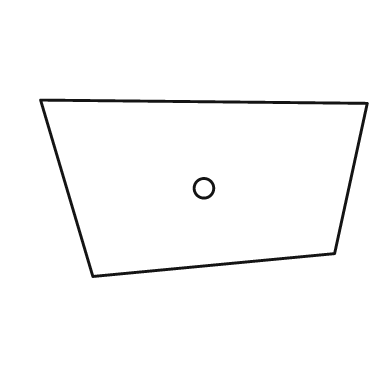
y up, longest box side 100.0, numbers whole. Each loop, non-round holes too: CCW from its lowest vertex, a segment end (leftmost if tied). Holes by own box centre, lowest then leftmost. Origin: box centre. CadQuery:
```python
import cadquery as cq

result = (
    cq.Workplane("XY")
    .moveTo(-34.0, -27.0)
    .lineTo(40.0, -20.0)
    .lineTo(50.0, 26.0)
    .lineTo(-50.0, 27.0)
    .close()
    .moveTo(0.0, 0.0)
    .circle(3.0)
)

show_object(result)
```